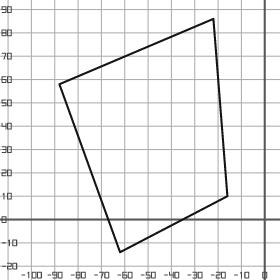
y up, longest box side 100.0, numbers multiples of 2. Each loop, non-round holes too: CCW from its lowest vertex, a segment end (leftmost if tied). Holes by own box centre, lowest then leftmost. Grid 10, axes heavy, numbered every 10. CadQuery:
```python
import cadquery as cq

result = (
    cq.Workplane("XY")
    .moveTo(-62.0, -14.0)
    .lineTo(-16.0, 10.0)
    .lineTo(-22.0, 86.0)
    .lineTo(-88.0, 58.0)
    .close()
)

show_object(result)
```